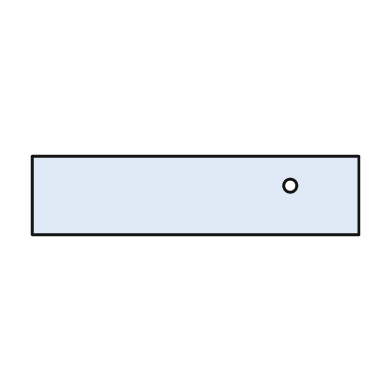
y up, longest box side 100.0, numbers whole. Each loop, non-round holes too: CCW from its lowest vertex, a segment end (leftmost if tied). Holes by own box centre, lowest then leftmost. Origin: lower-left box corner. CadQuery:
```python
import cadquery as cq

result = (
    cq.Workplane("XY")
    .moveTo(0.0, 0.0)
    .lineTo(100.0, 0.0)
    .lineTo(100.0, 24.0)
    .lineTo(0.0, 24.0)
    .close()
    .moveTo(79.0, 15.0)
    .circle(2.0)
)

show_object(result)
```